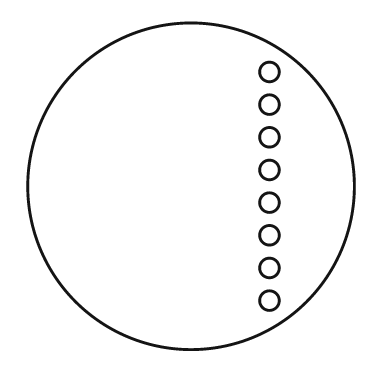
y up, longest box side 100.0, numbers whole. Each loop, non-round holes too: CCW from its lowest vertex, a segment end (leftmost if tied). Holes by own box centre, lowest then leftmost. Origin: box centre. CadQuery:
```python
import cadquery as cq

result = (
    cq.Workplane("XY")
    .moveTo(0.0, 0.0)
    .circle(50.0)
    .moveTo(24.0, -35.0)
    .circle(3.0)
    .moveTo(24.0, -25.0)
    .circle(3.0)
    .moveTo(24.0, -15.0)
    .circle(3.0)
    .moveTo(24.0, -5.0)
    .circle(3.0)
    .moveTo(24.0, 5.0)
    .circle(3.0)
    .moveTo(24.0, 15.0)
    .circle(3.0)
    .moveTo(24.0, 25.0)
    .circle(3.0)
    .moveTo(24.0, 35.0)
    .circle(3.0)
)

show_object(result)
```